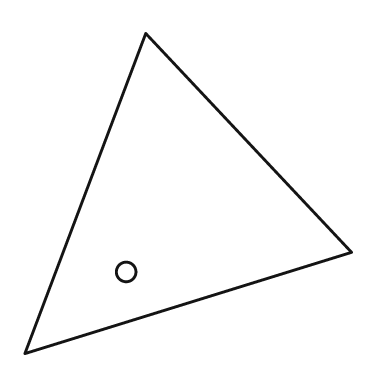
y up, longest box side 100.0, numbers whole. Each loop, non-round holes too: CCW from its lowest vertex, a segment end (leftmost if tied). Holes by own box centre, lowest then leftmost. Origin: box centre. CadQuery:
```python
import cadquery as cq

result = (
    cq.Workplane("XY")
    .moveTo(-50.0, -49.0)
    .lineTo(50.0, -18.0)
    .lineTo(-13.0, 49.0)
    .close()
    .moveTo(-19.0, -24.0)
    .circle(3.0)
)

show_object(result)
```